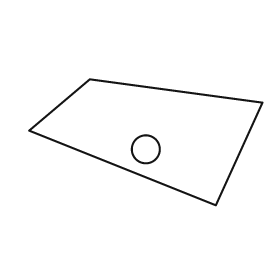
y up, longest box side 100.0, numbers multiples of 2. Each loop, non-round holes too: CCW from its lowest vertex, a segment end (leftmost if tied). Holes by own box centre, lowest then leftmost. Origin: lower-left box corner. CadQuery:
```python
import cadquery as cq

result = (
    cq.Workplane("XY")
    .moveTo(80.0, 0.0)
    .lineTo(100.0, 44.0)
    .lineTo(26.0, 54.0)
    .lineTo(0.0, 32.0)
    .close()
    .moveTo(50.0, 24.0)
    .circle(6.0)
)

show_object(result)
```